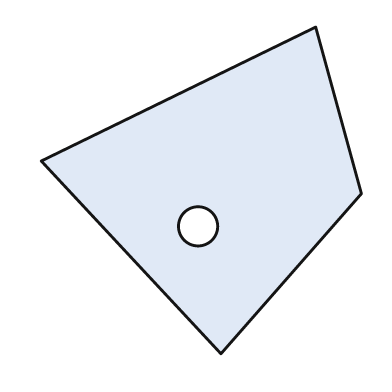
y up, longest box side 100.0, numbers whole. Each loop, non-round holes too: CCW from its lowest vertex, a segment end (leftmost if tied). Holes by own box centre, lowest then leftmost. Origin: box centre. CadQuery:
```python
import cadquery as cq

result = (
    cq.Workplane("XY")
    .moveTo(6.0, -50.0)
    .lineTo(49.0, -1.0)
    .lineTo(35.0, 50.0)
    .lineTo(-49.0, 9.0)
    .close()
    .moveTo(-1.0, -11.0)
    .circle(6.0)
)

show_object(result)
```